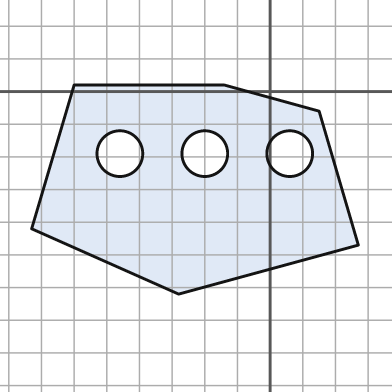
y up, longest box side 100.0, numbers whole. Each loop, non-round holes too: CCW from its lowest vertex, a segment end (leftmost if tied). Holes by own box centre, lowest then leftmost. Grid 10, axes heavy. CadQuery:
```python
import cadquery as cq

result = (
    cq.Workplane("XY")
    .moveTo(-28.0, -62.0)
    .lineTo(27.0, -47.0)
    .lineTo(15.0, -6.0)
    .lineTo(-14.0, 2.0)
    .lineTo(-60.0, 2.0)
    .lineTo(-73.0, -42.0)
    .close()
    .moveTo(-46.0, -19.0)
    .circle(7.0)
    .moveTo(-20.0, -19.0)
    .circle(7.0)
    .moveTo(6.0, -19.0)
    .circle(7.0)
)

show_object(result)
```